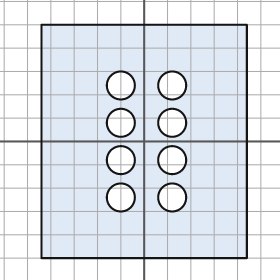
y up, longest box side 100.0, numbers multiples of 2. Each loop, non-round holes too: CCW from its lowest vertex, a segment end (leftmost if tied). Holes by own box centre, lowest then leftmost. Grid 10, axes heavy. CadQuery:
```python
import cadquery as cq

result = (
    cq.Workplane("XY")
    .moveTo(-44.0, -50.0)
    .lineTo(44.0, -50.0)
    .lineTo(44.0, 50.0)
    .lineTo(-44.0, 50.0)
    .close()
    .moveTo(-10.0, -24.0)
    .circle(6.0)
    .moveTo(12.0, -24.0)
    .circle(6.0)
    .moveTo(-10.0, -8.0)
    .circle(6.0)
    .moveTo(12.0, -8.0)
    .circle(6.0)
    .moveTo(-10.0, 8.0)
    .circle(6.0)
    .moveTo(12.0, 8.0)
    .circle(6.0)
    .moveTo(-10.0, 24.0)
    .circle(6.0)
    .moveTo(12.0, 24.0)
    .circle(6.0)
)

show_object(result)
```